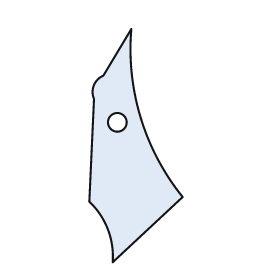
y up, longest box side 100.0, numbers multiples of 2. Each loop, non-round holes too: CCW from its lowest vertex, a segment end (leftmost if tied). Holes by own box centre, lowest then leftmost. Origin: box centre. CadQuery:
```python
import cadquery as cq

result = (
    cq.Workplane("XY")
    .moveTo(-10.0, -50.0)
    .lineTo(20.0, -22.0)
    .threePointArc((2.0, 12.0), (-2.0, 50.0))
    .lineTo(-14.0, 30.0)
    .threePointArc((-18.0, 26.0), (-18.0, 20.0))
    .lineTo(-20.0, -24.0)
    .threePointArc((-12.0, -36.0), (-10.0, -50.0))
    .close()
    .moveTo(-8.0, 10.0)
    .circle(4.0)
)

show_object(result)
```